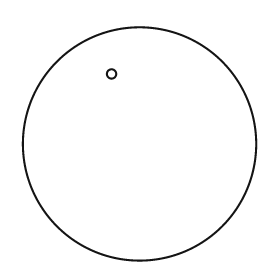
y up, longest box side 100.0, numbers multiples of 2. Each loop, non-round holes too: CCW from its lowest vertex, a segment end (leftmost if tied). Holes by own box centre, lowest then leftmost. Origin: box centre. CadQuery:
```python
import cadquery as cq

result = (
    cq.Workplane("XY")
    .moveTo(0.0, 0.0)
    .circle(50.0)
    .moveTo(-12.0, 30.0)
    .circle(2.0)
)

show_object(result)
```